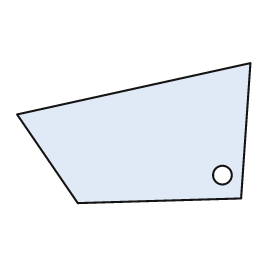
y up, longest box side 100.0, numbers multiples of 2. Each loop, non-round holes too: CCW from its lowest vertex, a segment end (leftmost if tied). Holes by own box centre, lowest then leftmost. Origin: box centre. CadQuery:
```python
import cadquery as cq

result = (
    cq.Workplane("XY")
    .moveTo(-24.0, -30.0)
    .lineTo(46.0, -28.0)
    .lineTo(50.0, 30.0)
    .lineTo(-50.0, 8.0)
    .close()
    .moveTo(38.0, -18.0)
    .circle(4.0)
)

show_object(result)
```